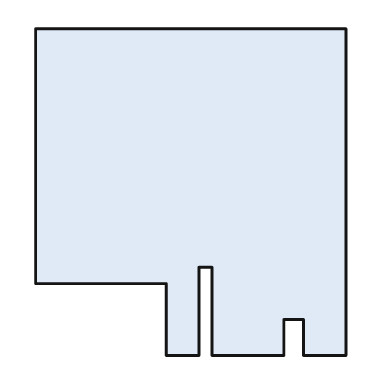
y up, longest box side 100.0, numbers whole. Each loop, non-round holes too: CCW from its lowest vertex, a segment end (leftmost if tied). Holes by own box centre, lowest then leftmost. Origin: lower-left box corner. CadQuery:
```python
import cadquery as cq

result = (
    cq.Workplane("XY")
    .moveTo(40.0, 0.0)
    .lineTo(50.0, 0.0)
    .lineTo(50.0, 27.0)
    .lineTo(54.0, 27.0)
    .lineTo(54.0, 0.0)
    .lineTo(76.0, 0.0)
    .lineTo(76.0, 11.0)
    .lineTo(82.0, 11.0)
    .lineTo(82.0, 0.0)
    .lineTo(95.0, 0.0)
    .lineTo(95.0, 100.0)
    .lineTo(0.0, 100.0)
    .lineTo(0.0, 22.0)
    .lineTo(40.0, 22.0)
    .close()
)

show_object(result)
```